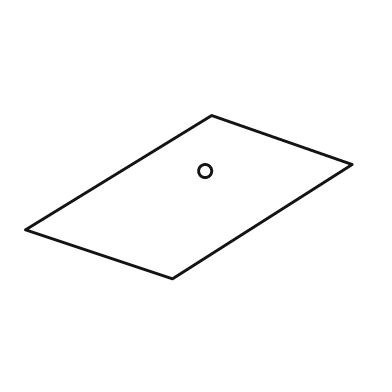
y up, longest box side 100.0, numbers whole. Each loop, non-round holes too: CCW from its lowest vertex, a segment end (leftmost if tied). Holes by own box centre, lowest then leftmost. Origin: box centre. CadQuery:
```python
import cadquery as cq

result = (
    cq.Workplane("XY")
    .moveTo(-5.0, -25.0)
    .lineTo(50.0, 10.0)
    .lineTo(7.0, 25.0)
    .lineTo(-50.0, -10.0)
    .close()
    .moveTo(5.0, 8.0)
    .circle(2.0)
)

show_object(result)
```